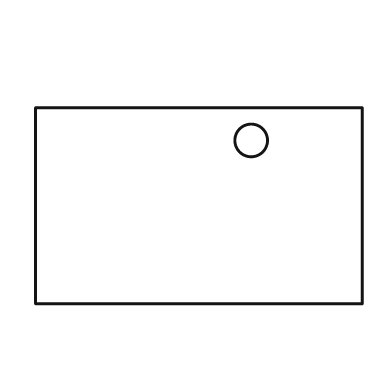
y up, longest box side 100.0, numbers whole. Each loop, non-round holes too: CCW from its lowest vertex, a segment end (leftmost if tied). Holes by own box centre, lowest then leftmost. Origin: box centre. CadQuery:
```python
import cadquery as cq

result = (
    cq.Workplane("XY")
    .moveTo(-50.0, -30.0)
    .lineTo(50.0, -30.0)
    .lineTo(50.0, 30.0)
    .lineTo(-50.0, 30.0)
    .close()
    .moveTo(16.0, 20.0)
    .circle(5.0)
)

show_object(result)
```